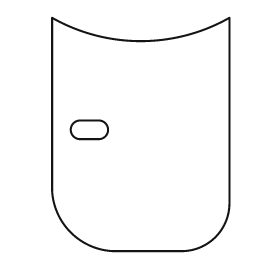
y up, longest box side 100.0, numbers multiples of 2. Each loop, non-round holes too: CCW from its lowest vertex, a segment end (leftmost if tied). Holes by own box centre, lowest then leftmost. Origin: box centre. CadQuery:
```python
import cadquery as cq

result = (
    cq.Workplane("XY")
    .moveTo(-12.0, -50.0)
    .lineTo(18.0, -50.0)
    .threePointArc((32.0, -44.0), (38.0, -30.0))
    .lineTo(38.0, 50.0)
    .threePointArc((0.0, 40.0), (-38.0, 50.0))
    .lineTo(-38.0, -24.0)
    .threePointArc((-30.0, -42.0), (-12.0, -50.0))
    .close()
    .moveTo(-26.0, -2.0)
    .lineTo(-18.0, -2.0)
    .threePointArc((-14.0, 2.0), (-18.0, 6.0))
    .lineTo(-26.0, 6.0)
    .threePointArc((-30.0, 2.0), (-26.0, -2.0))
    .close()
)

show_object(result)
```